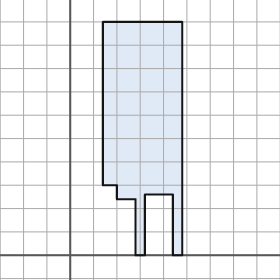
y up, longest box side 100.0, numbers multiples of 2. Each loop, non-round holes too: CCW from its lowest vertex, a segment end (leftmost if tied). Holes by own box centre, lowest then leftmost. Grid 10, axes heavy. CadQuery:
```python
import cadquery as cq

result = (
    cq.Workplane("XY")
    .moveTo(28.0, 0.0)
    .lineTo(32.0, 0.0)
    .lineTo(32.0, 26.0)
    .lineTo(44.0, 26.0)
    .lineTo(44.0, 0.0)
    .lineTo(48.0, 0.0)
    .lineTo(48.0, 100.0)
    .lineTo(14.0, 100.0)
    .lineTo(14.0, 30.0)
    .lineTo(20.0, 30.0)
    .lineTo(20.0, 24.0)
    .lineTo(28.0, 24.0)
    .close()
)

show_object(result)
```